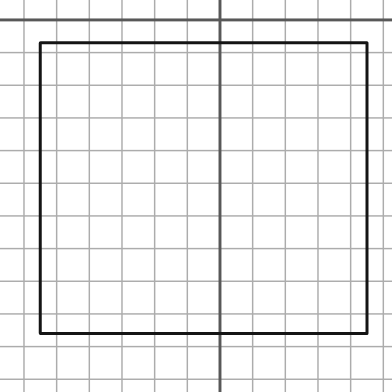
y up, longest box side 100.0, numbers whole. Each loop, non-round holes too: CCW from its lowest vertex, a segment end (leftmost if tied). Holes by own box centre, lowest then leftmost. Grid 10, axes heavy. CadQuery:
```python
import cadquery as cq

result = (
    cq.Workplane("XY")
    .moveTo(-55.0, -96.0)
    .lineTo(45.0, -96.0)
    .lineTo(45.0, -7.0)
    .lineTo(-55.0, -7.0)
    .close()
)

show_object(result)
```